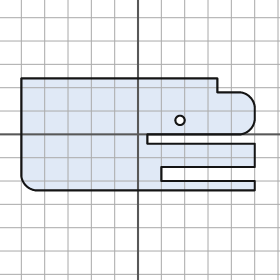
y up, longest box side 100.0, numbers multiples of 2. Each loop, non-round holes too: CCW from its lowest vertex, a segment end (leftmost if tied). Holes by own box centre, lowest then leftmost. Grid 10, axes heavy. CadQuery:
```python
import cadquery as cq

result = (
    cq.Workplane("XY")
    .moveTo(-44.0, -24.0)
    .lineTo(50.0, -24.0)
    .lineTo(50.0, -20.0)
    .lineTo(10.0, -20.0)
    .lineTo(10.0, -14.0)
    .lineTo(50.0, -14.0)
    .lineTo(50.0, -4.0)
    .lineTo(4.0, -4.0)
    .lineTo(4.0, 0.0)
    .lineTo(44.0, 0.0)
    .threePointArc((48.0, 2.0), (50.0, 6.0))
    .lineTo(50.0, 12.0)
    .threePointArc((48.0, 16.0), (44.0, 18.0))
    .lineTo(34.0, 18.0)
    .lineTo(34.0, 24.0)
    .lineTo(-50.0, 24.0)
    .lineTo(-50.0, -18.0)
    .threePointArc((-48.0, -22.0), (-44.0, -24.0))
    .close()
    .moveTo(18.0, 6.0)
    .circle(2.0)
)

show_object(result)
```